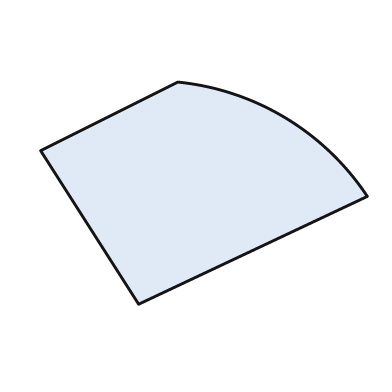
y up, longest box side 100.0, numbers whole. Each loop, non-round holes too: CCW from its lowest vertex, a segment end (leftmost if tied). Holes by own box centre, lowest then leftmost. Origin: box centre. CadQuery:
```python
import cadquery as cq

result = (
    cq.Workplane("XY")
    .moveTo(-20.0, -34.0)
    .lineTo(50.0, -1.0)
    .threePointArc((25.0, 23.0), (-8.0, 34.0))
    .lineTo(-50.0, 13.0)
    .close()
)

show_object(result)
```